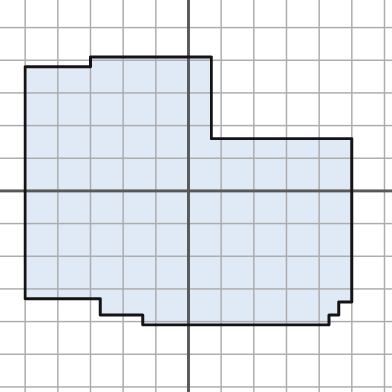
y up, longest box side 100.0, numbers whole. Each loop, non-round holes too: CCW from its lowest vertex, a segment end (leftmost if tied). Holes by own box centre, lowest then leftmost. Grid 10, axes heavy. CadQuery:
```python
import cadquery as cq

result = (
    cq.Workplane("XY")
    .moveTo(-14.0, -41.0)
    .lineTo(43.0, -41.0)
    .lineTo(43.0, -38.0)
    .lineTo(46.0, -38.0)
    .lineTo(46.0, -34.0)
    .lineTo(50.0, -34.0)
    .lineTo(50.0, 16.0)
    .lineTo(7.0, 16.0)
    .lineTo(7.0, 41.0)
    .lineTo(-30.0, 41.0)
    .lineTo(-30.0, 38.0)
    .lineTo(-50.0, 38.0)
    .lineTo(-50.0, -33.0)
    .lineTo(-27.0, -33.0)
    .lineTo(-27.0, -38.0)
    .lineTo(-14.0, -38.0)
    .close()
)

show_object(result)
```